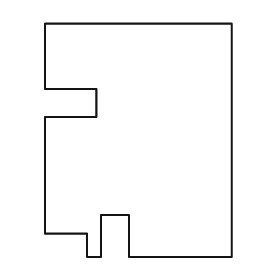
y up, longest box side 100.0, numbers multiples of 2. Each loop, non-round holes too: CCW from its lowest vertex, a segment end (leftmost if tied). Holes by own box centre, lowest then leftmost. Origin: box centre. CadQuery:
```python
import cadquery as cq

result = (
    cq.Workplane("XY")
    .moveTo(-22.0, -50.0)
    .lineTo(-16.0, -50.0)
    .lineTo(-16.0, -32.0)
    .lineTo(-4.0, -32.0)
    .lineTo(-4.0, -50.0)
    .lineTo(40.0, -50.0)
    .lineTo(40.0, 50.0)
    .lineTo(-40.0, 50.0)
    .lineTo(-40.0, 22.0)
    .lineTo(-18.0, 22.0)
    .lineTo(-18.0, 10.0)
    .lineTo(-40.0, 10.0)
    .lineTo(-40.0, -40.0)
    .lineTo(-22.0, -40.0)
    .close()
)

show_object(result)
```